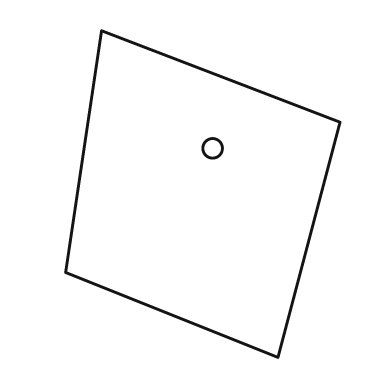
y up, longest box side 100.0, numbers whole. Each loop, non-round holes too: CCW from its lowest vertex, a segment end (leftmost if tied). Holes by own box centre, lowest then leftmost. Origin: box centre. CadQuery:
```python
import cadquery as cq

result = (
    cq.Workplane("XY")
    .moveTo(23.0, -50.0)
    .lineTo(42.0, 22.0)
    .lineTo(-31.0, 50.0)
    .lineTo(-42.0, -24.0)
    .close()
    .moveTo(3.0, 14.0)
    .circle(3.0)
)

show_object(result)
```